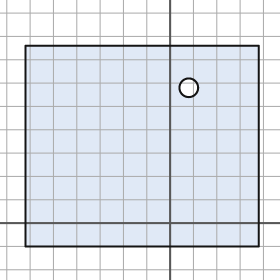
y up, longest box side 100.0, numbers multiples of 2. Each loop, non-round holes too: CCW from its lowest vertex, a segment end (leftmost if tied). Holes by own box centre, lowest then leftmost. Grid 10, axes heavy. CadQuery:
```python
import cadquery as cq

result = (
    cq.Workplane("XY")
    .moveTo(-62.0, -10.0)
    .lineTo(38.0, -10.0)
    .lineTo(38.0, 76.0)
    .lineTo(-62.0, 76.0)
    .close()
    .moveTo(8.0, 58.0)
    .circle(4.0)
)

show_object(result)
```